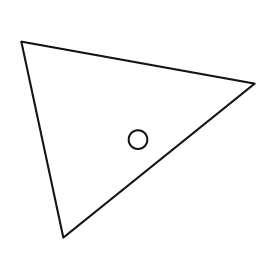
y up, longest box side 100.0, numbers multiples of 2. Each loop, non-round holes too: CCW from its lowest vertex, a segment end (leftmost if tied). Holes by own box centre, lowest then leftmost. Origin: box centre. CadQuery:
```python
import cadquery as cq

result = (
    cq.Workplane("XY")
    .moveTo(-32.0, -42.0)
    .lineTo(50.0, 24.0)
    .lineTo(-50.0, 42.0)
    .close()
    .moveTo(0.0, 0.0)
    .circle(4.0)
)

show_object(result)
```